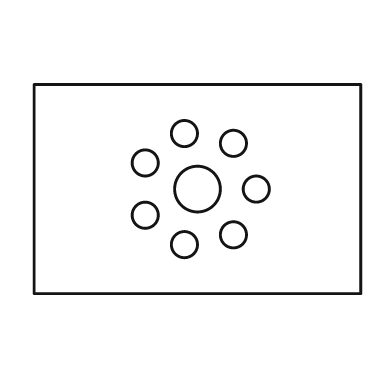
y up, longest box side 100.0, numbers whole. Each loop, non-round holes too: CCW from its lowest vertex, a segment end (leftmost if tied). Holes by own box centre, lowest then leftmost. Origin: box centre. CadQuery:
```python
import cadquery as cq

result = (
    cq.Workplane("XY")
    .moveTo(-50.0, -32.0)
    .lineTo(50.0, -32.0)
    .lineTo(50.0, 32.0)
    .lineTo(-50.0, 32.0)
    .close()
    .moveTo(-4.0, -17.0)
    .circle(4.0)
    .moveTo(11.0, -14.0)
    .circle(4.0)
    .moveTo(-16.0, -8.0)
    .circle(4.0)
    .moveTo(0.0, 0.0)
    .circle(7.0)
    .moveTo(18.0, 0.0)
    .circle(4.0)
    .moveTo(-16.0, 8.0)
    .circle(4.0)
    .moveTo(11.0, 14.0)
    .circle(4.0)
    .moveTo(-4.0, 17.0)
    .circle(4.0)
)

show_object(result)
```